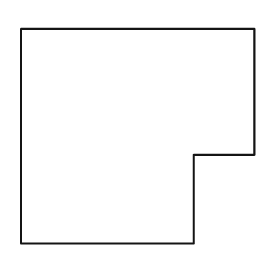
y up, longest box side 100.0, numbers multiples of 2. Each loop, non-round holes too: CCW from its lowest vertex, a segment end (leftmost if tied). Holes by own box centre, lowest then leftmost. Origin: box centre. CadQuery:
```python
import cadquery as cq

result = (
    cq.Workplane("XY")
    .moveTo(-50.0, -46.0)
    .lineTo(24.0, -46.0)
    .lineTo(24.0, -8.0)
    .lineTo(50.0, -8.0)
    .lineTo(50.0, 46.0)
    .lineTo(-50.0, 46.0)
    .close()
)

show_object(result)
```